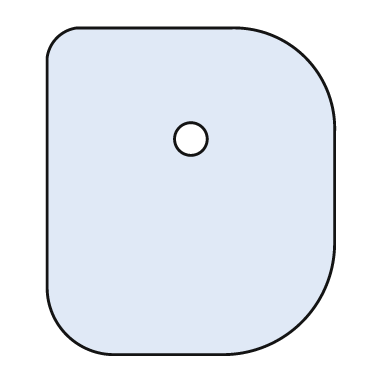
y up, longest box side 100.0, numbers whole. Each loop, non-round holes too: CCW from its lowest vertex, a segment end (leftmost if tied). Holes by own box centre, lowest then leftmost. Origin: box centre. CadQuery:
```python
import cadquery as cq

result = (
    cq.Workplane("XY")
    .moveTo(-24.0, -50.0)
    .lineTo(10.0, -50.0)
    .threePointArc((34.0, -40.0), (44.0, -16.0))
    .lineTo(44.0, 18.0)
    .threePointArc((35.0, 41.0), (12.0, 50.0))
    .lineTo(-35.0, 50.0)
    .threePointArc((-41.0, 47.0), (-44.0, 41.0))
    .lineTo(-44.0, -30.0)
    .threePointArc((-38.0, -44.0), (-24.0, -50.0))
    .close()
    .moveTo(0.0, 16.0)
    .circle(5.0)
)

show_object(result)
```